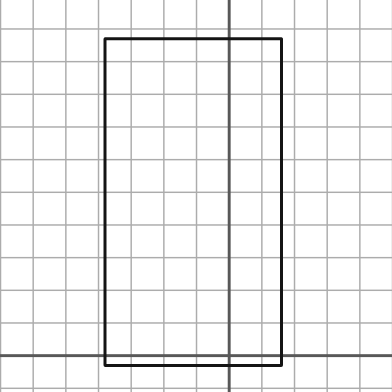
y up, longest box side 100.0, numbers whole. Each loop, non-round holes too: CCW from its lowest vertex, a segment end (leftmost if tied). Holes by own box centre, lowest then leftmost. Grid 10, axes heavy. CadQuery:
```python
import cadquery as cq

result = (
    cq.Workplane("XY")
    .moveTo(-38.0, -3.0)
    .lineTo(16.0, -3.0)
    .lineTo(16.0, 97.0)
    .lineTo(-38.0, 97.0)
    .close()
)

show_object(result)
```